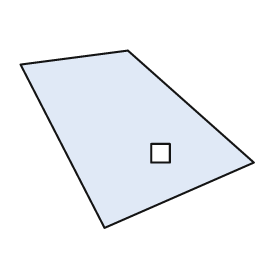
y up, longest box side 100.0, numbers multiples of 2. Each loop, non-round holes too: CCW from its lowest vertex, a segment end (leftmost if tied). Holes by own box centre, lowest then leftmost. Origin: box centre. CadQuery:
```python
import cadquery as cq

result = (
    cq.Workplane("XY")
    .moveTo(-14.0, -38.0)
    .lineTo(50.0, -10.0)
    .lineTo(-4.0, 38.0)
    .lineTo(-50.0, 32.0)
    .close()
    .moveTo(6.0, -10.0)
    .lineTo(14.0, -10.0)
    .lineTo(14.0, -2.0)
    .lineTo(6.0, -2.0)
    .close()
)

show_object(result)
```